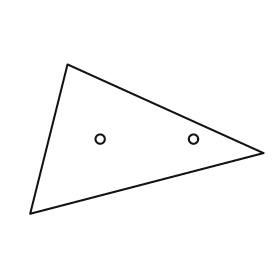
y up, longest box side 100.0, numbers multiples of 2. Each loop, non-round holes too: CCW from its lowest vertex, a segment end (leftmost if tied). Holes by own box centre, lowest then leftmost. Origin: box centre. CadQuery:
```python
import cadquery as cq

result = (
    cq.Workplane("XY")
    .moveTo(-50.0, -32.0)
    .lineTo(50.0, -6.0)
    .lineTo(-34.0, 32.0)
    .close()
    .moveTo(-20.0, 0.0)
    .circle(2.0)
    .moveTo(20.0, 0.0)
    .circle(2.0)
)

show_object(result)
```